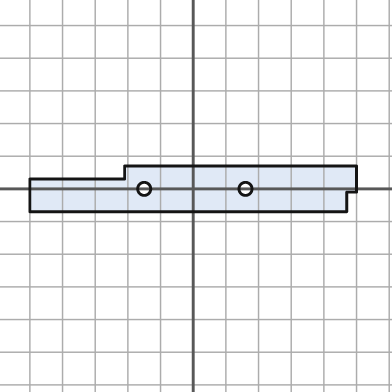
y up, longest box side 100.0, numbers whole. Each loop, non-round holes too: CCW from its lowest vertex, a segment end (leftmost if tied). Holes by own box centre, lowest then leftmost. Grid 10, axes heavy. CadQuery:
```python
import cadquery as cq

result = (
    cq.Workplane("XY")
    .moveTo(-50.0, -7.0)
    .lineTo(47.0, -7.0)
    .lineTo(47.0, -1.0)
    .lineTo(50.0, -1.0)
    .lineTo(50.0, 7.0)
    .lineTo(-21.0, 7.0)
    .lineTo(-21.0, 3.0)
    .lineTo(-50.0, 3.0)
    .close()
    .moveTo(-15.0, 0.0)
    .circle(2.0)
    .moveTo(16.0, 0.0)
    .circle(2.0)
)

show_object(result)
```